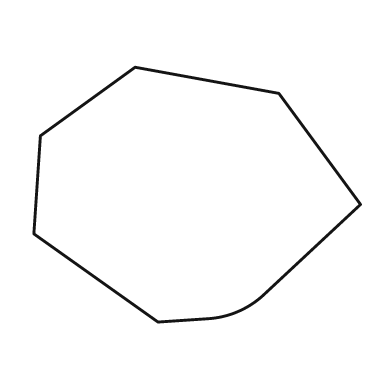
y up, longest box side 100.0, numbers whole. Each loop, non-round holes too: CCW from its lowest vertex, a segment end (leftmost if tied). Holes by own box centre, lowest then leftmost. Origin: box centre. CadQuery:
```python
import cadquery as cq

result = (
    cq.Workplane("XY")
    .moveTo(-12.0, -39.0)
    .lineTo(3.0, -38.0)
    .threePointArc((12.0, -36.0), (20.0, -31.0))
    .lineTo(50.0, -3.0)
    .lineTo(25.0, 31.0)
    .lineTo(-19.0, 39.0)
    .lineTo(-48.0, 18.0)
    .lineTo(-50.0, -12.0)
    .close()
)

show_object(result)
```